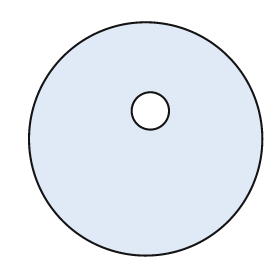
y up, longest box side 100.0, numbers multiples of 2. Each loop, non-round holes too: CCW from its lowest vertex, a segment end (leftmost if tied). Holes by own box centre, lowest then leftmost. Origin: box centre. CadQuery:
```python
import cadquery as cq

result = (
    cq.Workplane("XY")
    .moveTo(0.0, 0.0)
    .circle(50.0)
    .moveTo(2.0, 12.0)
    .circle(8.0)
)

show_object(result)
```